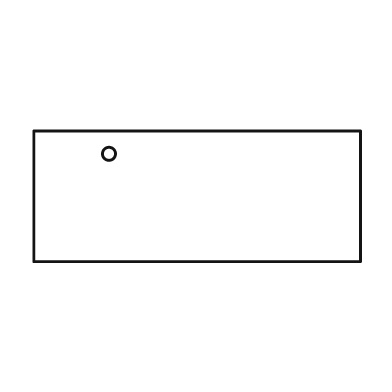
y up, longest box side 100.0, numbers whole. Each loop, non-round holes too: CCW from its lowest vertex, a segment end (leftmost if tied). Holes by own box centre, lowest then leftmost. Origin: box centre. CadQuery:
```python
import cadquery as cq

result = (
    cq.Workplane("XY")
    .moveTo(-50.0, -20.0)
    .lineTo(50.0, -20.0)
    .lineTo(50.0, 20.0)
    .lineTo(-50.0, 20.0)
    .close()
    .moveTo(-27.0, 13.0)
    .circle(2.0)
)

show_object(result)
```